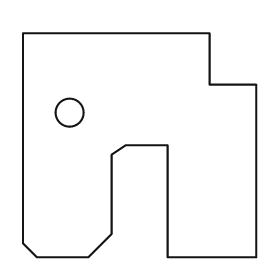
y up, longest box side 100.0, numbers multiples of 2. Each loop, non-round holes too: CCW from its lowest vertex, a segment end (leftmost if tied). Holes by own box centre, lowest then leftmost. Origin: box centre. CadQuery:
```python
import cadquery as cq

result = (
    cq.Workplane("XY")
    .moveTo(-44.0, -48.0)
    .lineTo(-22.0, -48.0)
    .lineTo(-12.0, -38.0)
    .lineTo(-12.0, -4.0)
    .lineTo(-6.0, 0.0)
    .lineTo(12.0, 0.0)
    .lineTo(12.0, -48.0)
    .lineTo(50.0, -48.0)
    .lineTo(50.0, 26.0)
    .lineTo(30.0, 26.0)
    .lineTo(30.0, 48.0)
    .lineTo(-50.0, 48.0)
    .lineTo(-50.0, -42.0)
    .close()
    .moveTo(-30.0, 14.0)
    .circle(6.0)
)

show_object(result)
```